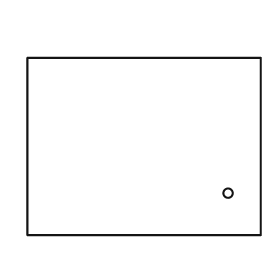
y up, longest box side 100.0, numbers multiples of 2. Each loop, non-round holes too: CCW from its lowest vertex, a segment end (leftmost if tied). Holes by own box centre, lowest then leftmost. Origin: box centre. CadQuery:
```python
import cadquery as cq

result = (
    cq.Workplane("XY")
    .moveTo(-50.0, -38.0)
    .lineTo(50.0, -38.0)
    .lineTo(50.0, 38.0)
    .lineTo(-50.0, 38.0)
    .close()
    .moveTo(36.0, -20.0)
    .circle(2.0)
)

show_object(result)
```